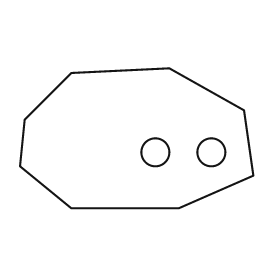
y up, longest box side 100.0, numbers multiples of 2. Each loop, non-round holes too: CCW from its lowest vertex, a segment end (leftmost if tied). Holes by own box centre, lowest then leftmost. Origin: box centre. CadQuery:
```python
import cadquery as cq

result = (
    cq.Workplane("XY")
    .moveTo(-28.0, -30.0)
    .lineTo(18.0, -30.0)
    .lineTo(50.0, -16.0)
    .lineTo(46.0, 12.0)
    .lineTo(14.0, 30.0)
    .lineTo(-28.0, 28.0)
    .lineTo(-48.0, 8.0)
    .lineTo(-50.0, -12.0)
    .close()
    .moveTo(8.0, -6.0)
    .circle(6.0)
    .moveTo(32.0, -6.0)
    .circle(6.0)
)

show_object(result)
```